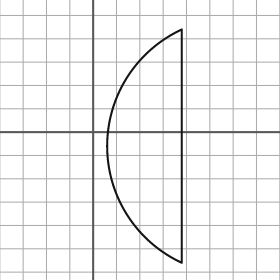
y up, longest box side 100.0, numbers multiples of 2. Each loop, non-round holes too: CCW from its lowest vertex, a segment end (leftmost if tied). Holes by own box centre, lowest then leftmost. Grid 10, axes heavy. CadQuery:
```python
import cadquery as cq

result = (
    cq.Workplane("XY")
    .moveTo(38.0, -56.0)
    .lineTo(38.0, 44.0)
    .threePointArc((6.0, -6.0), (38.0, -56.0))
    .close()
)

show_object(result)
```